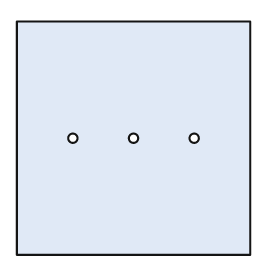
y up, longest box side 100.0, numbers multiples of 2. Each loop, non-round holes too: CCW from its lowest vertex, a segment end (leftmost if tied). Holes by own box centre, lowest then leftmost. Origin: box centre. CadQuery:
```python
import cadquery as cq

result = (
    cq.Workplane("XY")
    .moveTo(-50.0, -50.0)
    .lineTo(50.0, -50.0)
    .lineTo(50.0, 50.0)
    .lineTo(-50.0, 50.0)
    .close()
    .moveTo(-26.0, 0.0)
    .circle(2.0)
    .moveTo(0.0, 0.0)
    .circle(2.0)
    .moveTo(26.0, 0.0)
    .circle(2.0)
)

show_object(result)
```